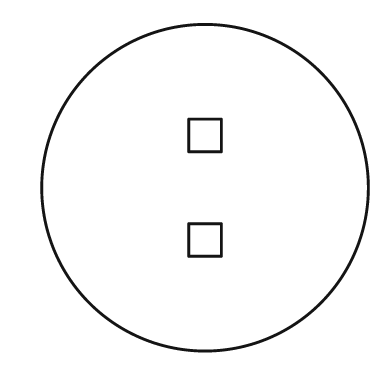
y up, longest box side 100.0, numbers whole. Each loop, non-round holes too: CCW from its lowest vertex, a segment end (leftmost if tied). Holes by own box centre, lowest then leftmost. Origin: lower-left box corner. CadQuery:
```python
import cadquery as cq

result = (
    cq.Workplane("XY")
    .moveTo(50.0, 50.0)
    .circle(50.0)
    .moveTo(45.0, 29.0)
    .lineTo(55.0, 29.0)
    .lineTo(55.0, 39.0)
    .lineTo(45.0, 39.0)
    .close()
    .moveTo(45.0, 61.0)
    .lineTo(55.0, 61.0)
    .lineTo(55.0, 71.0)
    .lineTo(45.0, 71.0)
    .close()
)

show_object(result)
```